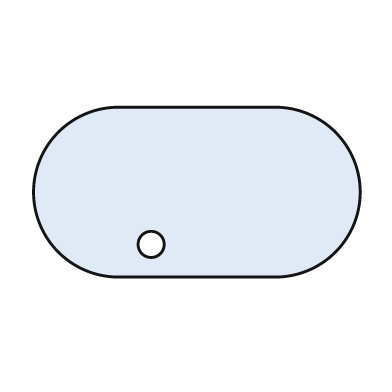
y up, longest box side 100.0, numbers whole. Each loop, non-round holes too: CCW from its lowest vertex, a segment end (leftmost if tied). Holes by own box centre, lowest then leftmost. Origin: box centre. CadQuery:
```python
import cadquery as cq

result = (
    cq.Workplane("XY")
    .moveTo(-24.0, -26.0)
    .lineTo(24.0, -26.0)
    .threePointArc((50.0, 0.0), (24.0, 26.0))
    .lineTo(-24.0, 26.0)
    .threePointArc((-50.0, 0.0), (-24.0, -26.0))
    .close()
    .moveTo(-14.0, -16.0)
    .circle(4.0)
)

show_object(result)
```